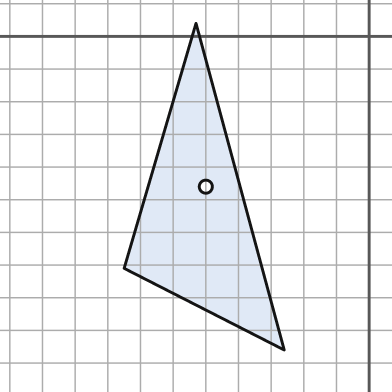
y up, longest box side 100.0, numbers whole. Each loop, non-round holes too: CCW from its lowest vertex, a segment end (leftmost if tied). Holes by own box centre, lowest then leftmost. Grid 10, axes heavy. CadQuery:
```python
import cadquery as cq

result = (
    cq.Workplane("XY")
    .moveTo(-26.0, -96.0)
    .lineTo(-53.0, 4.0)
    .lineTo(-75.0, -71.0)
    .close()
    .moveTo(-50.0, -46.0)
    .circle(2.0)
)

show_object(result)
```